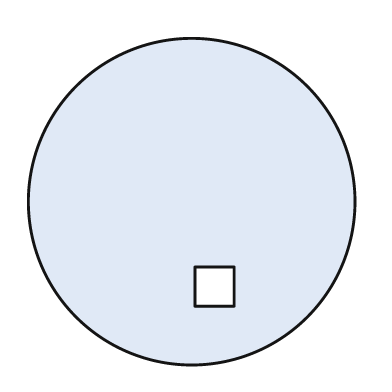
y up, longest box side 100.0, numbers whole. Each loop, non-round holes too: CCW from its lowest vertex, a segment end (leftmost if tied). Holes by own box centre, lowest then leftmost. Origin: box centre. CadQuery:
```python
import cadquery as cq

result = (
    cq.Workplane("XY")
    .moveTo(0.0, 0.0)
    .circle(50.0)
    .moveTo(1.0, -32.0)
    .lineTo(13.0, -32.0)
    .lineTo(13.0, -20.0)
    .lineTo(1.0, -20.0)
    .close()
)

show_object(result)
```